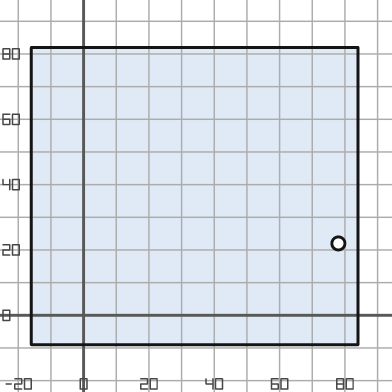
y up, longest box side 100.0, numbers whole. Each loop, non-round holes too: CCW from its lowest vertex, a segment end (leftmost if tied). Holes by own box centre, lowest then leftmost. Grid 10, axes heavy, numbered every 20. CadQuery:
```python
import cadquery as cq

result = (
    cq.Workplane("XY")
    .moveTo(-16.0, -9.0)
    .lineTo(84.0, -9.0)
    .lineTo(84.0, 82.0)
    .lineTo(-16.0, 82.0)
    .close()
    .moveTo(78.0, 22.0)
    .circle(2.0)
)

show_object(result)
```